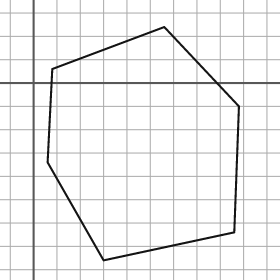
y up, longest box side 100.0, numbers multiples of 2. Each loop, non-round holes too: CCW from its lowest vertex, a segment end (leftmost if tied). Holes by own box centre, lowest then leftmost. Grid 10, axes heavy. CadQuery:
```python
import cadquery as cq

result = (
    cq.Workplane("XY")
    .moveTo(30.0, -76.0)
    .lineTo(86.0, -64.0)
    .lineTo(88.0, -10.0)
    .lineTo(56.0, 24.0)
    .lineTo(8.0, 6.0)
    .lineTo(6.0, -34.0)
    .close()
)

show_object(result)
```